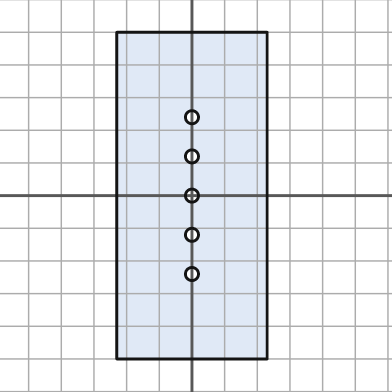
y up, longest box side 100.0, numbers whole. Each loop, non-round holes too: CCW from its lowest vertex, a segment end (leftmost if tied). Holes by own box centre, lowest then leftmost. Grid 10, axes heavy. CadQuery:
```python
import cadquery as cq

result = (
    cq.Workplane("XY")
    .moveTo(-23.0, -50.0)
    .lineTo(23.0, -50.0)
    .lineTo(23.0, 50.0)
    .lineTo(-23.0, 50.0)
    .close()
    .moveTo(0.0, -24.0)
    .circle(2.0)
    .moveTo(0.0, -12.0)
    .circle(2.0)
    .moveTo(0.0, 0.0)
    .circle(2.0)
    .moveTo(0.0, 12.0)
    .circle(2.0)
    .moveTo(0.0, 24.0)
    .circle(2.0)
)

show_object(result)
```